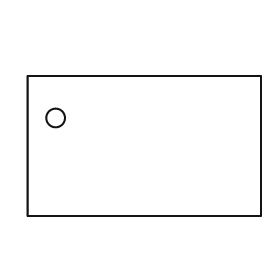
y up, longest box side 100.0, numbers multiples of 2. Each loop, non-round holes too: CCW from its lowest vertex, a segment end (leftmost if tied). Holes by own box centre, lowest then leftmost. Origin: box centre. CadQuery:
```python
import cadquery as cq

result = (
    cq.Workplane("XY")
    .moveTo(-50.0, -30.0)
    .lineTo(50.0, -30.0)
    .lineTo(50.0, 30.0)
    .lineTo(-50.0, 30.0)
    .close()
    .moveTo(-38.0, 12.0)
    .circle(4.0)
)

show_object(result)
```